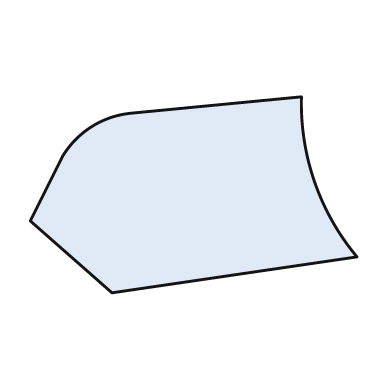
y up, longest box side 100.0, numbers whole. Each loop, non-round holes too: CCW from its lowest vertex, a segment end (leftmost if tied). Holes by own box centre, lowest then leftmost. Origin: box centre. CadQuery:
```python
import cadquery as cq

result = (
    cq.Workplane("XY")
    .moveTo(-25.0, -30.0)
    .lineTo(50.0, -19.0)
    .threePointArc((37.0, 4.0), (33.0, 30.0))
    .lineTo(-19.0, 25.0)
    .threePointArc((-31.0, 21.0), (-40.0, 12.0))
    .lineTo(-50.0, -8.0)
    .close()
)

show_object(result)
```